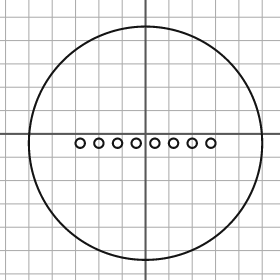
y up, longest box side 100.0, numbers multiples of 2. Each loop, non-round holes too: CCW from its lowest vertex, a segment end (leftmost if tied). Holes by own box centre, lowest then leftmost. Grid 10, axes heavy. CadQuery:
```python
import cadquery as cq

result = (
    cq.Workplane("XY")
    .moveTo(0.0, -4.0)
    .circle(50.0)
    .moveTo(-28.0, -4.0)
    .circle(2.0)
    .moveTo(-20.0, -4.0)
    .circle(2.0)
    .moveTo(-12.0, -4.0)
    .circle(2.0)
    .moveTo(-4.0, -4.0)
    .circle(2.0)
    .moveTo(4.0, -4.0)
    .circle(2.0)
    .moveTo(12.0, -4.0)
    .circle(2.0)
    .moveTo(20.0, -4.0)
    .circle(2.0)
    .moveTo(28.0, -4.0)
    .circle(2.0)
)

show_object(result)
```